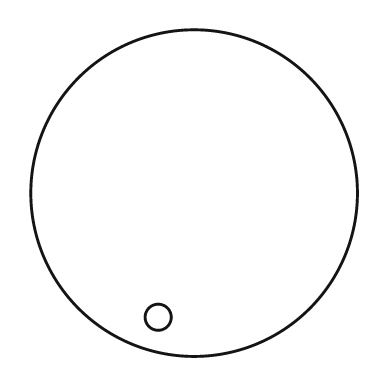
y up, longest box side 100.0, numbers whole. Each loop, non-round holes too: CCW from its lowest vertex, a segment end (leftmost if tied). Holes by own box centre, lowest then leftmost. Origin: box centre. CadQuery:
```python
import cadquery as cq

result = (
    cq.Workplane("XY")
    .moveTo(0.0, 0.0)
    .circle(50.0)
    .moveTo(-11.0, -38.0)
    .circle(4.0)
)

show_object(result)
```